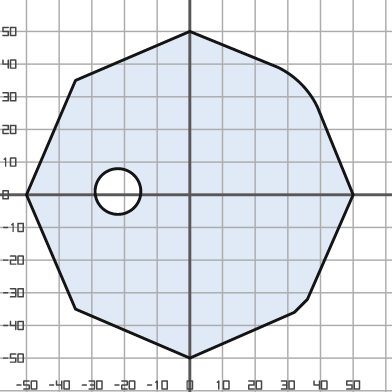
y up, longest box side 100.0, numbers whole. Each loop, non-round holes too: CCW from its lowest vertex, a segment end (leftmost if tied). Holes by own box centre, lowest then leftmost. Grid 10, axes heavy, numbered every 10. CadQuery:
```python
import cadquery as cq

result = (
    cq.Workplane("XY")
    .moveTo(0.0, -50.0)
    .lineTo(32.0, -36.0)
    .lineTo(36.0, -32.0)
    .lineTo(50.0, 0.0)
    .lineTo(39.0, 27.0)
    .threePointArc((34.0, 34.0), (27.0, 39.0))
    .lineTo(0.0, 50.0)
    .lineTo(-35.0, 35.0)
    .lineTo(-50.0, 0.0)
    .lineTo(-35.0, -35.0)
    .close()
    .moveTo(-22.0, 1.0)
    .circle(7.0)
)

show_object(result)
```